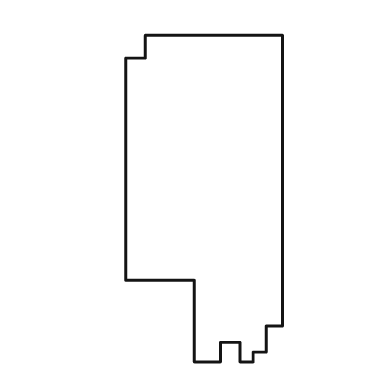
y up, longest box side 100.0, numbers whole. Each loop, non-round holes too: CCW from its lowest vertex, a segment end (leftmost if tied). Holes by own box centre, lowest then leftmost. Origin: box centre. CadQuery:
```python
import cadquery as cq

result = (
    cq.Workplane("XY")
    .moveTo(-3.0, -50.0)
    .lineTo(5.0, -50.0)
    .lineTo(5.0, -44.0)
    .lineTo(11.0, -44.0)
    .lineTo(11.0, -50.0)
    .lineTo(15.0, -50.0)
    .lineTo(15.0, -47.0)
    .lineTo(19.0, -47.0)
    .lineTo(19.0, -39.0)
    .lineTo(24.0, -39.0)
    .lineTo(24.0, 50.0)
    .lineTo(-18.0, 50.0)
    .lineTo(-18.0, 43.0)
    .lineTo(-24.0, 43.0)
    .lineTo(-24.0, -25.0)
    .lineTo(-3.0, -25.0)
    .close()
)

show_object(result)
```